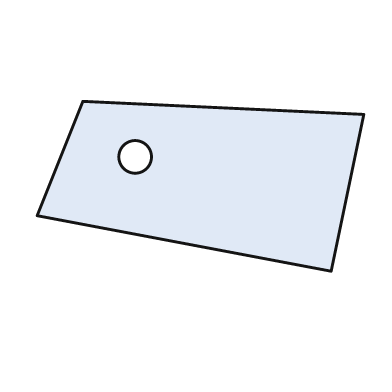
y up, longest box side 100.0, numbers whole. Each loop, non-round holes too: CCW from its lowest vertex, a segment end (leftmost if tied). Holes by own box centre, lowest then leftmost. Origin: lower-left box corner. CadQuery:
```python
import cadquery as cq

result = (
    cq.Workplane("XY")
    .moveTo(90.0, 0.0)
    .lineTo(100.0, 48.0)
    .lineTo(14.0, 52.0)
    .lineTo(0.0, 17.0)
    .close()
    .moveTo(30.0, 35.0)
    .circle(5.0)
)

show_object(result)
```